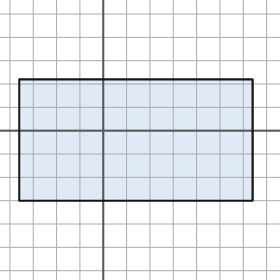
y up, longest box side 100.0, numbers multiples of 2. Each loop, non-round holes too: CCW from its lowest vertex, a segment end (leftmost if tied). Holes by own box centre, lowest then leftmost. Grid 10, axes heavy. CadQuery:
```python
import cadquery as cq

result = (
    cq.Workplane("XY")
    .moveTo(-36.0, -30.0)
    .lineTo(64.0, -30.0)
    .lineTo(64.0, 22.0)
    .lineTo(-36.0, 22.0)
    .close()
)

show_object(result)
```